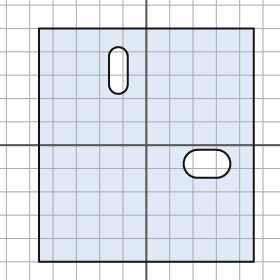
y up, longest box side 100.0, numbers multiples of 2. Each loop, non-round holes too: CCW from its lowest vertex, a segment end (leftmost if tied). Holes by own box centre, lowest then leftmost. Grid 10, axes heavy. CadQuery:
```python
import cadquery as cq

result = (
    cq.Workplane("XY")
    .moveTo(-46.0, -50.0)
    .lineTo(46.0, -50.0)
    .lineTo(46.0, 50.0)
    .lineTo(-46.0, 50.0)
    .close()
    .moveTo(22.0, -14.0)
    .lineTo(30.0, -14.0)
    .threePointArc((36.0, -8.0), (30.0, -2.0))
    .lineTo(22.0, -2.0)
    .threePointArc((16.0, -8.0), (22.0, -14.0))
    .close()
    .moveTo(-16.0, 26.0)
    .threePointArc((-12.0, 22.0), (-8.0, 26.0))
    .lineTo(-8.0, 38.0)
    .threePointArc((-12.0, 42.0), (-16.0, 38.0))
    .close()
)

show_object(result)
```